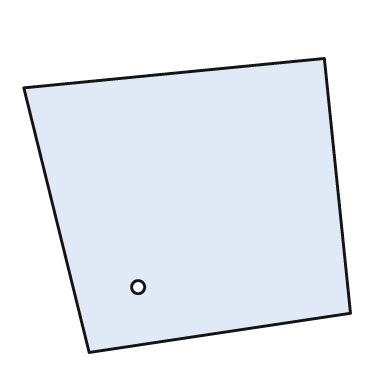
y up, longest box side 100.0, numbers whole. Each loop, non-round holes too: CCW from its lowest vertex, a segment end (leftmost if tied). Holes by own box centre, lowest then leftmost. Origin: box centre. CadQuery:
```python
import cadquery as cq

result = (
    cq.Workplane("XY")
    .moveTo(-30.0, -45.0)
    .lineTo(50.0, -33.0)
    .lineTo(42.0, 45.0)
    .lineTo(-50.0, 36.0)
    .close()
    .moveTo(-15.0, -25.0)
    .circle(2.0)
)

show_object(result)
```